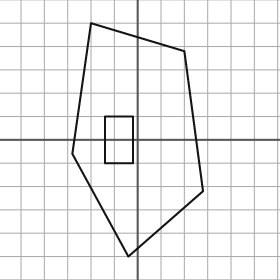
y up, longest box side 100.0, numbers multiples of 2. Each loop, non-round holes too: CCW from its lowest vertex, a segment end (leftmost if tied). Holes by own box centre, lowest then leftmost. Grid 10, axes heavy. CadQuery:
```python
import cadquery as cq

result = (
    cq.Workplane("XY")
    .moveTo(-4.0, -50.0)
    .lineTo(28.0, -22.0)
    .lineTo(20.0, 38.0)
    .lineTo(-20.0, 50.0)
    .lineTo(-28.0, -6.0)
    .close()
    .moveTo(-14.0, -10.0)
    .lineTo(-2.0, -10.0)
    .lineTo(-2.0, 10.0)
    .lineTo(-14.0, 10.0)
    .close()
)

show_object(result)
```